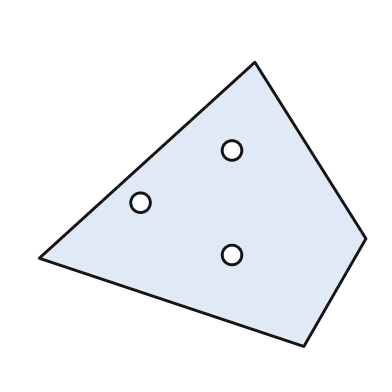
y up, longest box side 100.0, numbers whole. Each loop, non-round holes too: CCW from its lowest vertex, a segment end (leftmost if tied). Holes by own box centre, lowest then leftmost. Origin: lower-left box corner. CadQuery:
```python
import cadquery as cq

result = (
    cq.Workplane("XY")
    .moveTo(81.0, 0.0)
    .lineTo(100.0, 33.0)
    .lineTo(66.0, 87.0)
    .lineTo(0.0, 27.0)
    .close()
    .moveTo(59.0, 28.0)
    .circle(3.0)
    .moveTo(31.0, 44.0)
    .circle(3.0)
    .moveTo(59.0, 60.0)
    .circle(3.0)
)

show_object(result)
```